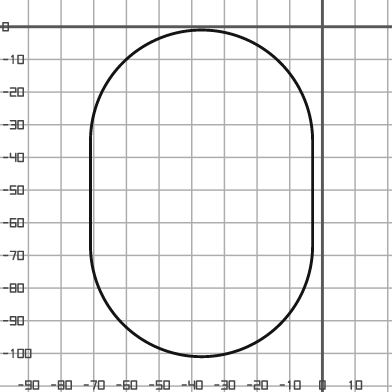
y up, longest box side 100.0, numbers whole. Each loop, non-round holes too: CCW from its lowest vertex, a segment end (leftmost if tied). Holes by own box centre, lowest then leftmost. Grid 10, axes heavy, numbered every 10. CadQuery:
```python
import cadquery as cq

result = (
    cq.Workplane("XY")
    .moveTo(-71.0, -67.0)
    .threePointArc((-37.0, -101.0), (-3.0, -67.0))
    .lineTo(-3.0, -35.0)
    .threePointArc((-37.0, -1.0), (-71.0, -35.0))
    .close()
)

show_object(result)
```